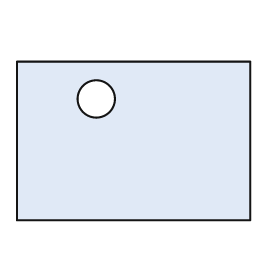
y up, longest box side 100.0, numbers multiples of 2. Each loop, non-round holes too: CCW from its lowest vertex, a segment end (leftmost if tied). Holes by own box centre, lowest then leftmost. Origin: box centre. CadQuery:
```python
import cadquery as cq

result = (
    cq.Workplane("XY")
    .moveTo(-50.0, -34.0)
    .lineTo(50.0, -34.0)
    .lineTo(50.0, 34.0)
    .lineTo(-50.0, 34.0)
    .close()
    .moveTo(-16.0, 18.0)
    .circle(8.0)
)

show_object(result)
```